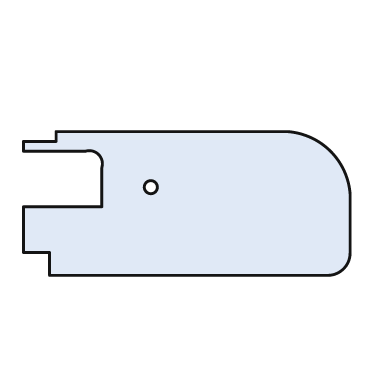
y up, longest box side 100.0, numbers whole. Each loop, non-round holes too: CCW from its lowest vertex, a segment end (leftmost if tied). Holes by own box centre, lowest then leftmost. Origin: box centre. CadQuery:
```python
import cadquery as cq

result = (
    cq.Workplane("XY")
    .moveTo(-42.0, -22.0)
    .lineTo(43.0, -22.0)
    .threePointArc((48.0, -20.0), (50.0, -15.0))
    .lineTo(50.0, 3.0)
    .threePointArc((44.0, 16.0), (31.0, 22.0))
    .lineTo(-40.0, 22.0)
    .lineTo(-40.0, 19.0)
    .lineTo(-50.0, 19.0)
    .lineTo(-50.0, 16.0)
    .lineTo(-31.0, 16.0)
    .threePointArc((-27.0, 15.0), (-26.0, 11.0))
    .lineTo(-26.0, -1.0)
    .lineTo(-50.0, -1.0)
    .lineTo(-50.0, -15.0)
    .lineTo(-42.0, -15.0)
    .close()
    .moveTo(-11.0, 5.0)
    .circle(2.0)
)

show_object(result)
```